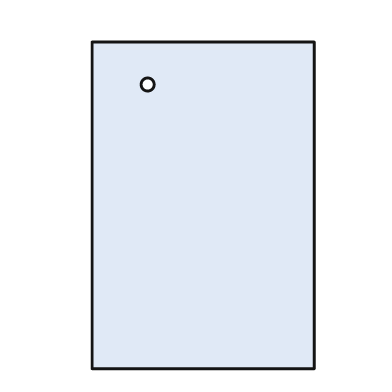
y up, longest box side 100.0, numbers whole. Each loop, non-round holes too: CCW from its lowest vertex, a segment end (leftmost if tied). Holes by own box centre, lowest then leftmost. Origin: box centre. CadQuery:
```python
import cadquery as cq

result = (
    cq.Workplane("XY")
    .moveTo(-34.0, -50.0)
    .lineTo(34.0, -50.0)
    .lineTo(34.0, 50.0)
    .lineTo(-34.0, 50.0)
    .close()
    .moveTo(-17.0, 37.0)
    .circle(2.0)
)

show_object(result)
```